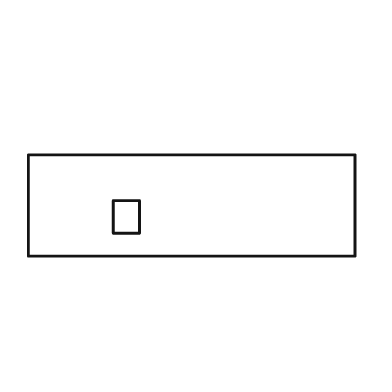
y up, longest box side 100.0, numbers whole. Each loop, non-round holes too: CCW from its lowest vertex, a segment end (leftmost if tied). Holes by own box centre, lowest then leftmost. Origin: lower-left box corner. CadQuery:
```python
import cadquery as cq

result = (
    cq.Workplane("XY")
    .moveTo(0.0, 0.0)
    .lineTo(100.0, 0.0)
    .lineTo(100.0, 31.0)
    .lineTo(0.0, 31.0)
    .close()
    .moveTo(26.0, 7.0)
    .lineTo(34.0, 7.0)
    .lineTo(34.0, 17.0)
    .lineTo(26.0, 17.0)
    .close()
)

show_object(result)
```